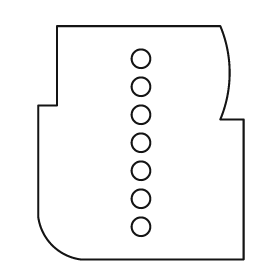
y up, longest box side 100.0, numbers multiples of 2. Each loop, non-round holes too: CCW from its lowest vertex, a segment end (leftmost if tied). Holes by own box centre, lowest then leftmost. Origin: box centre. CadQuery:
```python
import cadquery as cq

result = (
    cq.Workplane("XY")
    .moveTo(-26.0, -50.0)
    .lineTo(44.0, -50.0)
    .lineTo(44.0, 10.0)
    .lineTo(34.0, 10.0)
    .threePointArc((38.0, 30.0), (34.0, 50.0))
    .lineTo(-36.0, 50.0)
    .lineTo(-36.0, 16.0)
    .lineTo(-44.0, 16.0)
    .lineTo(-44.0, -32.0)
    .threePointArc((-38.0, -44.0), (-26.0, -50.0))
    .close()
    .moveTo(0.0, -36.0)
    .circle(4.0)
    .moveTo(0.0, -24.0)
    .circle(4.0)
    .moveTo(0.0, -12.0)
    .circle(4.0)
    .moveTo(0.0, 0.0)
    .circle(4.0)
    .moveTo(0.0, 12.0)
    .circle(4.0)
    .moveTo(0.0, 24.0)
    .circle(4.0)
    .moveTo(0.0, 36.0)
    .circle(4.0)
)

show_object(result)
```